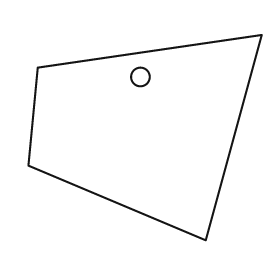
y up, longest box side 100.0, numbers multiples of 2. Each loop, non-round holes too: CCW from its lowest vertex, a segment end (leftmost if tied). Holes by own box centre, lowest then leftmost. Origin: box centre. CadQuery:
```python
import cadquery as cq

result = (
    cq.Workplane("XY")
    .moveTo(26.0, -44.0)
    .lineTo(50.0, 44.0)
    .lineTo(-46.0, 30.0)
    .lineTo(-50.0, -12.0)
    .close()
    .moveTo(-2.0, 26.0)
    .circle(4.0)
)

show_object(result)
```